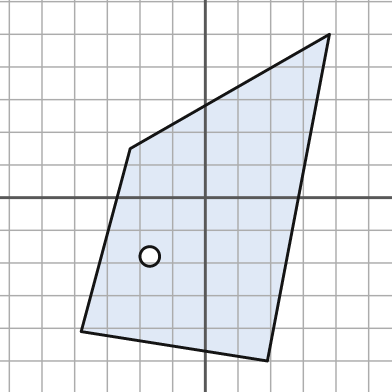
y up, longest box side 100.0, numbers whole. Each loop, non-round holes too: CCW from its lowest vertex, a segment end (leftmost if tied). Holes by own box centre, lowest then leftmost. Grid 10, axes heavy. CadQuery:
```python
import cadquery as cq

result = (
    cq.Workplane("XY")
    .moveTo(19.0, -50.0)
    .lineTo(38.0, 50.0)
    .lineTo(-23.0, 15.0)
    .lineTo(-38.0, -41.0)
    .close()
    .moveTo(-17.0, -18.0)
    .circle(3.0)
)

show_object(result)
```